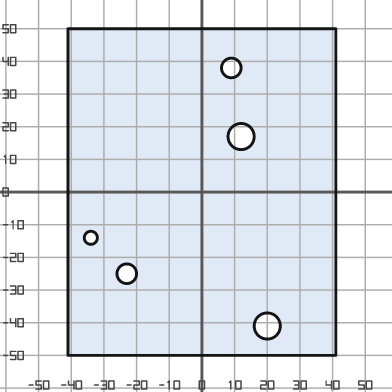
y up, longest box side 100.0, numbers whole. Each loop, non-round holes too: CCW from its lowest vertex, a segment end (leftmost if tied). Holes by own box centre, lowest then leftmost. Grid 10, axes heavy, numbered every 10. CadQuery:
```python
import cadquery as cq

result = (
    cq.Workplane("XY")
    .moveTo(-41.0, -50.0)
    .lineTo(41.0, -50.0)
    .lineTo(41.0, 50.0)
    .lineTo(-41.0, 50.0)
    .close()
    .moveTo(20.0, -41.0)
    .circle(4.0)
    .moveTo(-23.0, -25.0)
    .circle(3.0)
    .moveTo(-34.0, -14.0)
    .circle(2.0)
    .moveTo(12.0, 17.0)
    .circle(4.0)
    .moveTo(9.0, 38.0)
    .circle(3.0)
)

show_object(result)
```